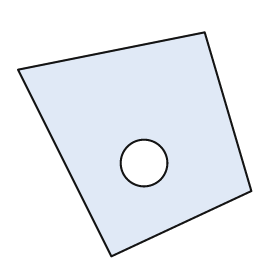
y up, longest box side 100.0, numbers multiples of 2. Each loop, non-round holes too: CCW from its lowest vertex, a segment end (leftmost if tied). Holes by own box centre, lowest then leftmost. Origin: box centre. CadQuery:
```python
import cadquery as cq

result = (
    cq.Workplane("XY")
    .moveTo(-10.0, -48.0)
    .lineTo(50.0, -20.0)
    .lineTo(30.0, 48.0)
    .lineTo(-50.0, 32.0)
    .close()
    .moveTo(4.0, -8.0)
    .circle(10.0)
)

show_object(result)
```